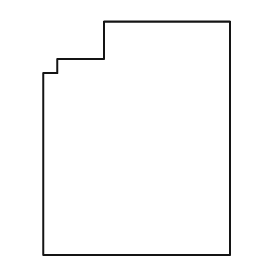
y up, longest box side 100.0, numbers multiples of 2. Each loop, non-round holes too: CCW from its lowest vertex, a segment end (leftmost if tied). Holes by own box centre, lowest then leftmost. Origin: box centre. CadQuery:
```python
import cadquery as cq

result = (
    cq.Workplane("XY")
    .moveTo(-40.0, -50.0)
    .lineTo(40.0, -50.0)
    .lineTo(40.0, 50.0)
    .lineTo(-14.0, 50.0)
    .lineTo(-14.0, 34.0)
    .lineTo(-34.0, 34.0)
    .lineTo(-34.0, 28.0)
    .lineTo(-40.0, 28.0)
    .close()
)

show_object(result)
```